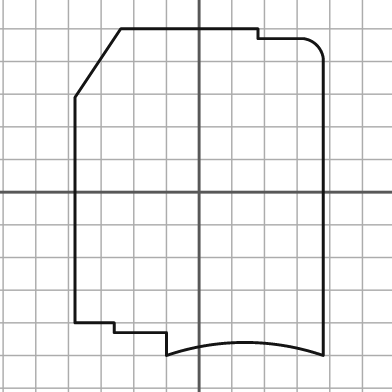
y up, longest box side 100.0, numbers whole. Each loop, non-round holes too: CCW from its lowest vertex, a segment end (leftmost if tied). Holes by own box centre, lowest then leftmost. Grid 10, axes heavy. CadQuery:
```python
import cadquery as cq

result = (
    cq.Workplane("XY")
    .moveTo(-10.0, -50.0)
    .threePointArc((14.0, -46.0), (38.0, -50.0))
    .lineTo(38.0, 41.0)
    .threePointArc((36.0, 45.0), (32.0, 47.0))
    .lineTo(18.0, 47.0)
    .lineTo(18.0, 50.0)
    .lineTo(-24.0, 50.0)
    .lineTo(-38.0, 29.0)
    .lineTo(-38.0, -40.0)
    .lineTo(-26.0, -40.0)
    .lineTo(-26.0, -43.0)
    .lineTo(-10.0, -43.0)
    .close()
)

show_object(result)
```